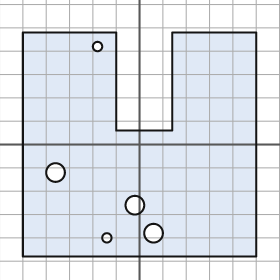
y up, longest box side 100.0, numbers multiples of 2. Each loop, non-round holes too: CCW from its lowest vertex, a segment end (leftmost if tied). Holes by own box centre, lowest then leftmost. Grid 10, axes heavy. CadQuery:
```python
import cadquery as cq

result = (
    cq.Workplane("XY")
    .moveTo(-50.0, -48.0)
    .lineTo(50.0, -48.0)
    .lineTo(50.0, 48.0)
    .lineTo(14.0, 48.0)
    .lineTo(14.0, 6.0)
    .lineTo(-10.0, 6.0)
    .lineTo(-10.0, 48.0)
    .lineTo(-50.0, 48.0)
    .close()
    .moveTo(-14.0, -40.0)
    .circle(2.0)
    .moveTo(6.0, -38.0)
    .circle(4.0)
    .moveTo(-2.0, -26.0)
    .circle(4.0)
    .moveTo(-36.0, -12.0)
    .circle(4.0)
    .moveTo(-18.0, 42.0)
    .circle(2.0)
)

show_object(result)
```